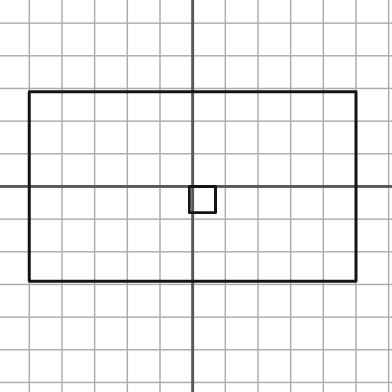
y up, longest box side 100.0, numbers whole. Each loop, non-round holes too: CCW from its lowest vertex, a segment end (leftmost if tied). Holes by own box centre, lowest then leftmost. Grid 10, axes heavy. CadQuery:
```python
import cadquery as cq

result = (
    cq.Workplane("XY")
    .moveTo(-50.0, -29.0)
    .lineTo(50.0, -29.0)
    .lineTo(50.0, 29.0)
    .lineTo(-50.0, 29.0)
    .close()
    .moveTo(-1.0, -8.0)
    .lineTo(7.0, -8.0)
    .lineTo(7.0, 0.0)
    .lineTo(-1.0, 0.0)
    .close()
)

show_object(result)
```